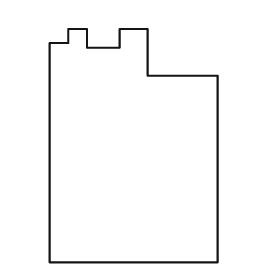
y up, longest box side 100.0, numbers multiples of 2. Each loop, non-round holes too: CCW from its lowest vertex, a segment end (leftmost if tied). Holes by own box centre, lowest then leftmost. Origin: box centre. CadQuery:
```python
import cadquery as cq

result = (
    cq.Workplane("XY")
    .moveTo(-36.0, -50.0)
    .lineTo(36.0, -50.0)
    .lineTo(36.0, 30.0)
    .lineTo(6.0, 30.0)
    .lineTo(6.0, 50.0)
    .lineTo(-6.0, 50.0)
    .lineTo(-6.0, 42.0)
    .lineTo(-20.0, 42.0)
    .lineTo(-20.0, 50.0)
    .lineTo(-28.0, 50.0)
    .lineTo(-28.0, 44.0)
    .lineTo(-36.0, 44.0)
    .close()
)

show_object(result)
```